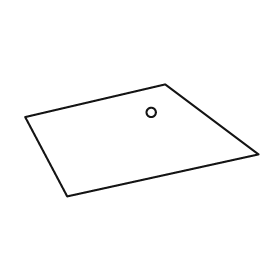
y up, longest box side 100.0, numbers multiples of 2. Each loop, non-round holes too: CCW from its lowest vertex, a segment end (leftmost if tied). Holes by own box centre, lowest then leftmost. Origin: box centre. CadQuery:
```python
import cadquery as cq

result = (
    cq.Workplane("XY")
    .moveTo(-32.0, -24.0)
    .lineTo(50.0, -6.0)
    .lineTo(10.0, 24.0)
    .lineTo(-50.0, 10.0)
    .close()
    .moveTo(4.0, 12.0)
    .circle(2.0)
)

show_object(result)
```